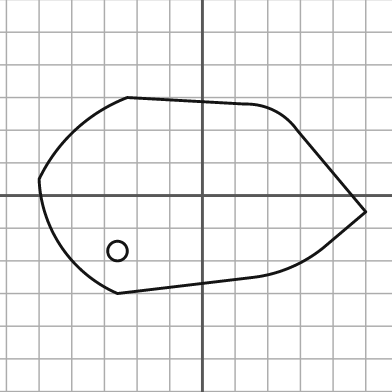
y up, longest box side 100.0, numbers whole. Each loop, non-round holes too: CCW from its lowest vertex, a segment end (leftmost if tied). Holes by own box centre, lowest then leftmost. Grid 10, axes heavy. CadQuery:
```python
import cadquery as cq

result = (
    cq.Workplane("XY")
    .moveTo(-26.0, -30.0)
    .lineTo(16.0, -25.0)
    .threePointArc((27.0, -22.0), (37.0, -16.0))
    .lineTo(50.0, -5.0)
    .lineTo(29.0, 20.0)
    .threePointArc((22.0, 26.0), (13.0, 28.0))
    .lineTo(-23.0, 30.0)
    .threePointArc((-39.0, 20.0), (-50.0, 5.0))
    .threePointArc((-43.0, -16.0), (-26.0, -30.0))
    .close()
    .moveTo(-26.0, -17.0)
    .circle(3.0)
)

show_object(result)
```